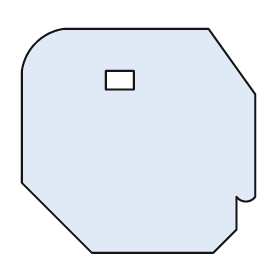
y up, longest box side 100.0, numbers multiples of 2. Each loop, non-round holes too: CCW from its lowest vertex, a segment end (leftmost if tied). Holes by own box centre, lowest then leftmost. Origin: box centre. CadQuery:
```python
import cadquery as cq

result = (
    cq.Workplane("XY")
    .moveTo(-20.0, -48.0)
    .lineTo(32.0, -48.0)
    .lineTo(42.0, -38.0)
    .lineTo(42.0, -24.0)
    .threePointArc((46.0, -26.0), (50.0, -24.0))
    .lineTo(50.0, 20.0)
    .lineTo(30.0, 48.0)
    .lineTo(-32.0, 48.0)
    .threePointArc((-44.0, 42.0), (-50.0, 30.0))
    .lineTo(-50.0, -18.0)
    .close()
    .moveTo(-14.0, 22.0)
    .lineTo(-2.0, 22.0)
    .lineTo(-2.0, 30.0)
    .lineTo(-14.0, 30.0)
    .close()
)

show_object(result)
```